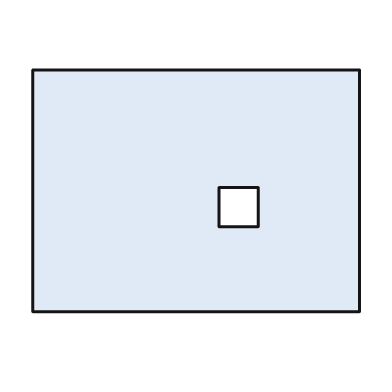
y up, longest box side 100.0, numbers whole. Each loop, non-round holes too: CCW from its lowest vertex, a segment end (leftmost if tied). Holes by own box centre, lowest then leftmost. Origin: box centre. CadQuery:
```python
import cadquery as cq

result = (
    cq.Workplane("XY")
    .moveTo(-50.0, -37.0)
    .lineTo(50.0, -37.0)
    .lineTo(50.0, 37.0)
    .lineTo(-50.0, 37.0)
    .close()
    .moveTo(7.0, -11.0)
    .lineTo(19.0, -11.0)
    .lineTo(19.0, 1.0)
    .lineTo(7.0, 1.0)
    .close()
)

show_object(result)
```